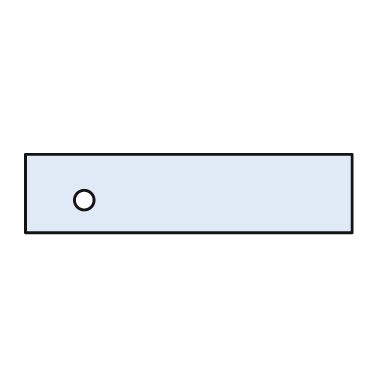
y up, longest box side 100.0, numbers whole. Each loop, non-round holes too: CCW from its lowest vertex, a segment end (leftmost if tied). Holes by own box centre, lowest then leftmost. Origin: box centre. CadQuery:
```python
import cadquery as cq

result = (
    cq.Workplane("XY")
    .moveTo(-50.0, -12.0)
    .lineTo(50.0, -12.0)
    .lineTo(50.0, 12.0)
    .lineTo(-50.0, 12.0)
    .close()
    .moveTo(-32.0, -2.0)
    .circle(3.0)
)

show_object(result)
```